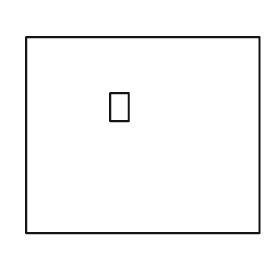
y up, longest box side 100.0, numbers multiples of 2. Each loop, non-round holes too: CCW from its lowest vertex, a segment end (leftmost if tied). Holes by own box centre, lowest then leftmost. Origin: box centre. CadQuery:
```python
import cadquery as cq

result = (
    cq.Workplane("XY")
    .moveTo(-50.0, -42.0)
    .lineTo(50.0, -42.0)
    .lineTo(50.0, 42.0)
    .lineTo(-50.0, 42.0)
    .close()
    .moveTo(-14.0, 6.0)
    .lineTo(-6.0, 6.0)
    .lineTo(-6.0, 18.0)
    .lineTo(-14.0, 18.0)
    .close()
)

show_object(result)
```